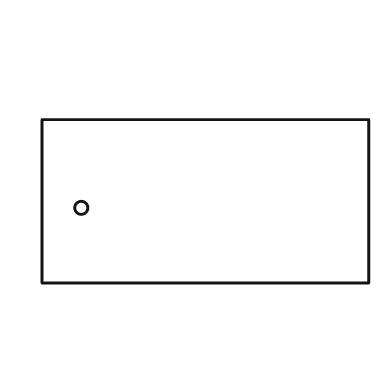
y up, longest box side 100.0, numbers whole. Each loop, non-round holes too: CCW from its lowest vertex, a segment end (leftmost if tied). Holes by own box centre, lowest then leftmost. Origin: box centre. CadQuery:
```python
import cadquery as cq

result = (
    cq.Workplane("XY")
    .moveTo(-50.0, -25.0)
    .lineTo(50.0, -25.0)
    .lineTo(50.0, 25.0)
    .lineTo(-50.0, 25.0)
    .close()
    .moveTo(-38.0, -2.0)
    .circle(2.0)
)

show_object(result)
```